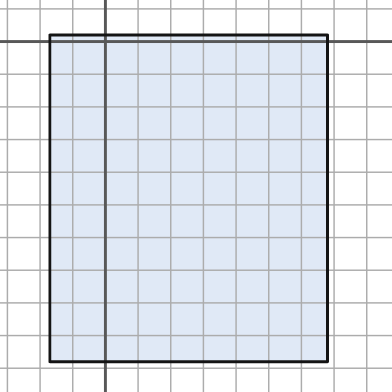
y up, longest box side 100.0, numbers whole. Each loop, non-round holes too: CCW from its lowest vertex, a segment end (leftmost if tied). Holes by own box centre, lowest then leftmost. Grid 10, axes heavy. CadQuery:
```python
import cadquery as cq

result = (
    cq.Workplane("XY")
    .moveTo(-17.0, -98.0)
    .lineTo(68.0, -98.0)
    .lineTo(68.0, 2.0)
    .lineTo(-17.0, 2.0)
    .close()
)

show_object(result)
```